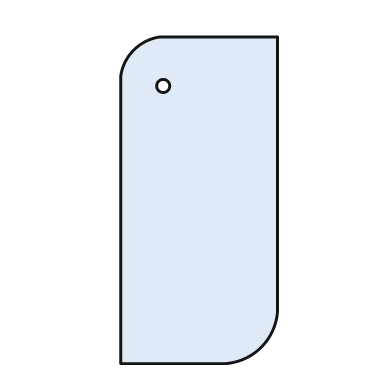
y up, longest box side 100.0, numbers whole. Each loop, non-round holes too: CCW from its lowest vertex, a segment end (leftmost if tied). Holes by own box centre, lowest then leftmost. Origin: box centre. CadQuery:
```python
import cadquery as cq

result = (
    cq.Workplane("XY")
    .moveTo(-24.0, -50.0)
    .lineTo(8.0, -50.0)
    .threePointArc((19.0, -45.0), (24.0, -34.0))
    .lineTo(24.0, 50.0)
    .lineTo(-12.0, 50.0)
    .threePointArc((-20.0, 46.0), (-24.0, 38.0))
    .close()
    .moveTo(-11.0, 35.0)
    .circle(2.0)
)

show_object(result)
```